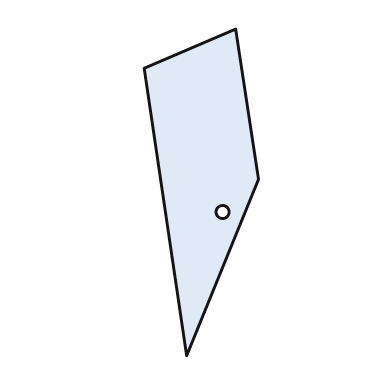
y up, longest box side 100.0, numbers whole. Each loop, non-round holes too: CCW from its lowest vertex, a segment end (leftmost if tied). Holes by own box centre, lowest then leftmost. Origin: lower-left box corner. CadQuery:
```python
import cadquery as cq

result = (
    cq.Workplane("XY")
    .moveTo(13.0, 0.0)
    .lineTo(35.0, 54.0)
    .lineTo(28.0, 100.0)
    .lineTo(0.0, 88.0)
    .close()
    .moveTo(24.0, 44.0)
    .circle(2.0)
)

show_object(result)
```